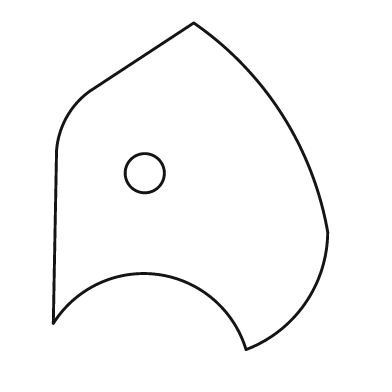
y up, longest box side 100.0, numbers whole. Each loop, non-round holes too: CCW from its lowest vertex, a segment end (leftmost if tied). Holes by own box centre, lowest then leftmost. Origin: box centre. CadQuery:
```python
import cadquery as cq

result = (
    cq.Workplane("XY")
    .moveTo(17.0, -50.0)
    .threePointArc((35.0, -36.0), (42.0, -14.0))
    .threePointArc((28.0, 22.0), (1.0, 50.0))
    .lineTo(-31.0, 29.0)
    .threePointArc((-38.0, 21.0), (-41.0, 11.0))
    .lineTo(-42.0, -42.0)
    .threePointArc((-10.0, -27.0), (17.0, -50.0))
    .close()
    .moveTo(-14.0, 4.0)
    .circle(6.0)
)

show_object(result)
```